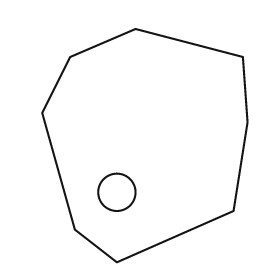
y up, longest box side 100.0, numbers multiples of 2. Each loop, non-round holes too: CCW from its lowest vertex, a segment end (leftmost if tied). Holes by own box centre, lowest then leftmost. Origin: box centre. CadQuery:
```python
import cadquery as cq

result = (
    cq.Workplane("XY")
    .moveTo(-12.0, -50.0)
    .lineTo(38.0, -28.0)
    .lineTo(44.0, 10.0)
    .lineTo(42.0, 38.0)
    .lineTo(-4.0, 50.0)
    .lineTo(-32.0, 38.0)
    .lineTo(-44.0, 14.0)
    .lineTo(-30.0, -36.0)
    .close()
    .moveTo(-12.0, -20.0)
    .circle(8.0)
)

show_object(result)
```